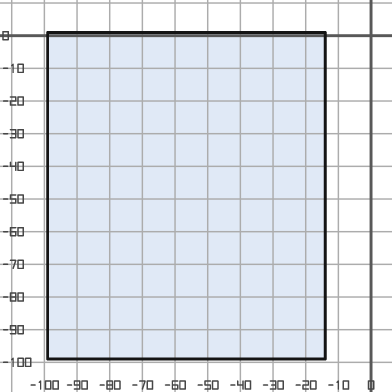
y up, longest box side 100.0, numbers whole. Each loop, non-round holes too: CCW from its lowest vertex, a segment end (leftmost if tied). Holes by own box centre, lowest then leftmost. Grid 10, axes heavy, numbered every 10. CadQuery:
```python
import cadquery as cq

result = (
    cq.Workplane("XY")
    .moveTo(-99.0, -99.0)
    .lineTo(-14.0, -99.0)
    .lineTo(-14.0, 1.0)
    .lineTo(-99.0, 1.0)
    .close()
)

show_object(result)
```